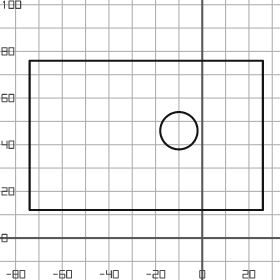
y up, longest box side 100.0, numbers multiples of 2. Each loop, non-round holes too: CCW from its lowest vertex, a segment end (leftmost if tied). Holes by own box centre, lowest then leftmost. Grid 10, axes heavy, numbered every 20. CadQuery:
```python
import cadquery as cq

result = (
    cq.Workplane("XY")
    .moveTo(-74.0, 12.0)
    .lineTo(26.0, 12.0)
    .lineTo(26.0, 76.0)
    .lineTo(-74.0, 76.0)
    .close()
    .moveTo(-10.0, 46.0)
    .circle(8.0)
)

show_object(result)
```